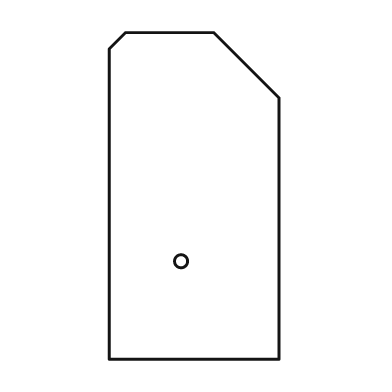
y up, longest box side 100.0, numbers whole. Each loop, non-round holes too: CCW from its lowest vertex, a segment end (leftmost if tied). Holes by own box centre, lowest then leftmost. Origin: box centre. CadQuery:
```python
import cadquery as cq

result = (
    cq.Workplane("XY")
    .moveTo(-26.0, -50.0)
    .lineTo(26.0, -50.0)
    .lineTo(26.0, 30.0)
    .lineTo(6.0, 50.0)
    .lineTo(-21.0, 50.0)
    .lineTo(-26.0, 45.0)
    .close()
    .moveTo(-4.0, -20.0)
    .circle(2.0)
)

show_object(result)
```